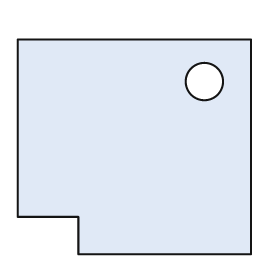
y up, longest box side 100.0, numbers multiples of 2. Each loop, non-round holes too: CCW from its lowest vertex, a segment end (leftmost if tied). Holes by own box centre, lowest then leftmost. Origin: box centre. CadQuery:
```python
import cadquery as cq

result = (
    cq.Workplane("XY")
    .moveTo(-24.0, -46.0)
    .lineTo(50.0, -46.0)
    .lineTo(50.0, 46.0)
    .lineTo(-50.0, 46.0)
    .lineTo(-50.0, -30.0)
    .lineTo(-24.0, -30.0)
    .close()
    .moveTo(30.0, 28.0)
    .circle(8.0)
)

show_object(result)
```